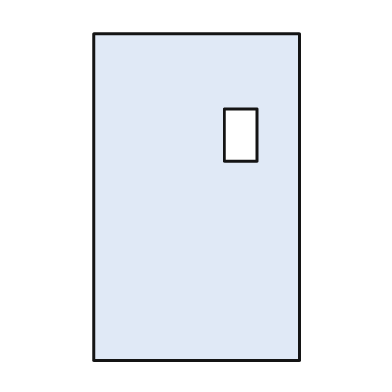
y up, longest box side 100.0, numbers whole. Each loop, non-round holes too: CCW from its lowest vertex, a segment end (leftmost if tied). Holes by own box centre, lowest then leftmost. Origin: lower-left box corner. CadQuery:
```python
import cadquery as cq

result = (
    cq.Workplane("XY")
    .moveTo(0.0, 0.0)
    .lineTo(63.0, 0.0)
    .lineTo(63.0, 100.0)
    .lineTo(0.0, 100.0)
    .close()
    .moveTo(40.0, 61.0)
    .lineTo(50.0, 61.0)
    .lineTo(50.0, 77.0)
    .lineTo(40.0, 77.0)
    .close()
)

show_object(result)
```